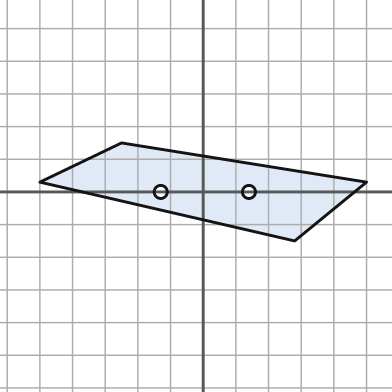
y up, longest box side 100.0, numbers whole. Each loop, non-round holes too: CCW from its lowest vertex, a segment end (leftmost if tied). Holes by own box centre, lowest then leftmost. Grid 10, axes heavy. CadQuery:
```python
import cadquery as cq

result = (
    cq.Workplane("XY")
    .moveTo(28.0, -15.0)
    .lineTo(50.0, 3.0)
    .lineTo(-25.0, 15.0)
    .lineTo(-50.0, 3.0)
    .close()
    .moveTo(-13.0, 0.0)
    .circle(2.0)
    .moveTo(14.0, 0.0)
    .circle(2.0)
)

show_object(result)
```